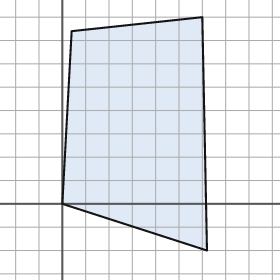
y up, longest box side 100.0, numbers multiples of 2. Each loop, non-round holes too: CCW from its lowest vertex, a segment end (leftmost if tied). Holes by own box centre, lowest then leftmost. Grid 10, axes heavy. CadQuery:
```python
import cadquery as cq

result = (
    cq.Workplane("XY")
    .moveTo(62.0, -20.0)
    .lineTo(60.0, 80.0)
    .lineTo(4.0, 74.0)
    .lineTo(0.0, 0.0)
    .close()
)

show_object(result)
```